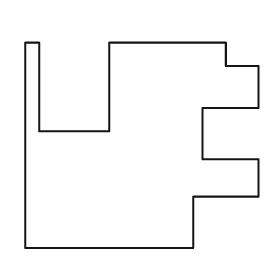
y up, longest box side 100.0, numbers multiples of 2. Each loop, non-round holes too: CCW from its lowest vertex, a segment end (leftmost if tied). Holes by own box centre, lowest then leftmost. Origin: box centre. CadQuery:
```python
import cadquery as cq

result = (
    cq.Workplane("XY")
    .moveTo(-50.0, -44.0)
    .lineTo(22.0, -44.0)
    .lineTo(22.0, -22.0)
    .lineTo(50.0, -22.0)
    .lineTo(50.0, -6.0)
    .lineTo(26.0, -6.0)
    .lineTo(26.0, 16.0)
    .lineTo(50.0, 16.0)
    .lineTo(50.0, 34.0)
    .lineTo(36.0, 34.0)
    .lineTo(36.0, 44.0)
    .lineTo(-14.0, 44.0)
    .lineTo(-14.0, 6.0)
    .lineTo(-44.0, 6.0)
    .lineTo(-44.0, 44.0)
    .lineTo(-50.0, 44.0)
    .close()
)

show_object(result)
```